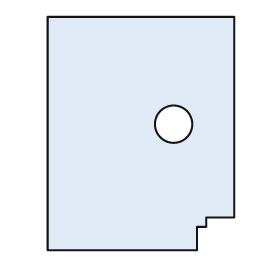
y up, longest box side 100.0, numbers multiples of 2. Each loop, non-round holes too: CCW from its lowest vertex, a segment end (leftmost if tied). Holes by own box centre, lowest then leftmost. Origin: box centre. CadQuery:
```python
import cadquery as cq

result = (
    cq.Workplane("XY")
    .moveTo(-40.0, -50.0)
    .lineTo(24.0, -50.0)
    .lineTo(24.0, -40.0)
    .lineTo(28.0, -40.0)
    .lineTo(28.0, -36.0)
    .lineTo(40.0, -36.0)
    .lineTo(40.0, 50.0)
    .lineTo(-40.0, 50.0)
    .close()
    .moveTo(14.0, 4.0)
    .circle(8.0)
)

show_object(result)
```